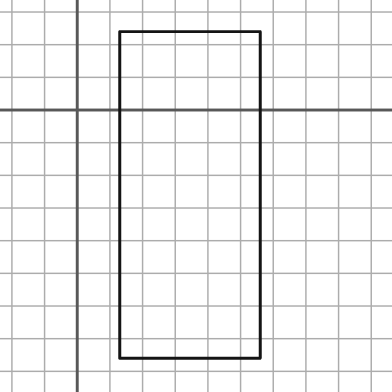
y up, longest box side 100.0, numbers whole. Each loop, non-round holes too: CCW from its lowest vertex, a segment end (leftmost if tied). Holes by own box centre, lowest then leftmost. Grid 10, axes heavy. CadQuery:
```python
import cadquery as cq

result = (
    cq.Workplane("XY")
    .moveTo(13.0, -76.0)
    .lineTo(56.0, -76.0)
    .lineTo(56.0, 24.0)
    .lineTo(13.0, 24.0)
    .close()
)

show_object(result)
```